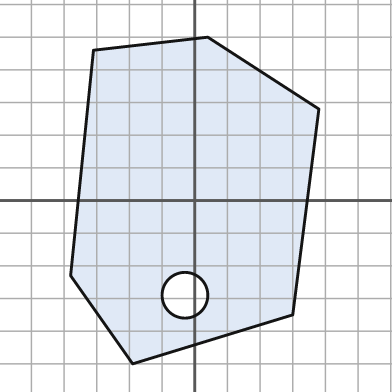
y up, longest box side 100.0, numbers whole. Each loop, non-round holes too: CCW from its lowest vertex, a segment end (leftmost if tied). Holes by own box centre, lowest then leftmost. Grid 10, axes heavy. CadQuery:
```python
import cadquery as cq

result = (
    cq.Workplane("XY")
    .moveTo(-19.0, -50.0)
    .lineTo(30.0, -35.0)
    .lineTo(38.0, 28.0)
    .lineTo(4.0, 50.0)
    .lineTo(-31.0, 46.0)
    .lineTo(-38.0, -23.0)
    .close()
    .moveTo(-3.0, -29.0)
    .circle(7.0)
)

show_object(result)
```